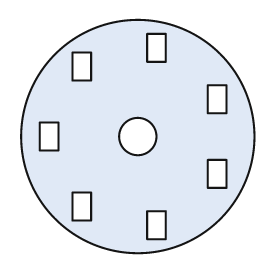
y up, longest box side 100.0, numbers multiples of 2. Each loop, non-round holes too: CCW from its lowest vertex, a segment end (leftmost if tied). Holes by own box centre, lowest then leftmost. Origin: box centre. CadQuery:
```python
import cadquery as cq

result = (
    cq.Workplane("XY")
    .moveTo(0.0, 0.0)
    .circle(50.0)
    .moveTo(4.0, -44.0)
    .lineTo(12.0, -44.0)
    .lineTo(12.0, -32.0)
    .lineTo(4.0, -32.0)
    .close()
    .moveTo(-28.0, -36.0)
    .lineTo(-20.0, -36.0)
    .lineTo(-20.0, -24.0)
    .lineTo(-28.0, -24.0)
    .close()
    .moveTo(30.0, -22.0)
    .lineTo(38.0, -22.0)
    .lineTo(38.0, -10.0)
    .lineTo(30.0, -10.0)
    .close()
    .moveTo(-42.0, -6.0)
    .lineTo(-34.0, -6.0)
    .lineTo(-34.0, 6.0)
    .lineTo(-42.0, 6.0)
    .close()
    .moveTo(0.0, 0.0)
    .circle(8.0)
    .moveTo(30.0, 10.0)
    .lineTo(38.0, 10.0)
    .lineTo(38.0, 22.0)
    .lineTo(30.0, 22.0)
    .close()
    .moveTo(-28.0, 24.0)
    .lineTo(-20.0, 24.0)
    .lineTo(-20.0, 36.0)
    .lineTo(-28.0, 36.0)
    .close()
    .moveTo(4.0, 32.0)
    .lineTo(12.0, 32.0)
    .lineTo(12.0, 44.0)
    .lineTo(4.0, 44.0)
    .close()
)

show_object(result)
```